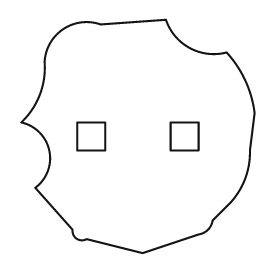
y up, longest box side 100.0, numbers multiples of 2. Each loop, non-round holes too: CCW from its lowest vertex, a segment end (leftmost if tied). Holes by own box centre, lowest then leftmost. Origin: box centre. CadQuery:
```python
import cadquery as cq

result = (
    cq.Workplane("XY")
    .moveTo(2.0, -50.0)
    .lineTo(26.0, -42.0)
    .threePointArc((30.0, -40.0), (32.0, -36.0))
    .lineTo(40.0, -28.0)
    .threePointArc((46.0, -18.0), (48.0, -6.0))
    .lineTo(50.0, 10.0)
    .threePointArc((46.0, 24.0), (38.0, 36.0))
    .threePointArc((22.0, 38.0), (12.0, 50.0))
    .lineTo(-16.0, 48.0)
    .threePointArc((-32.0, 46.0), (-40.0, 32.0))
    .threePointArc((-42.0, 18.0), (-50.0, 6.0))
    .threePointArc((-38.0, -6.0), (-44.0, -22.0))
    .lineTo(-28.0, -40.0)
    .threePointArc((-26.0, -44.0), (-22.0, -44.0))
    .close()
    .moveTo(-26.0, -6.0)
    .lineTo(-14.0, -6.0)
    .lineTo(-14.0, 6.0)
    .lineTo(-26.0, 6.0)
    .close()
    .moveTo(14.0, -6.0)
    .lineTo(26.0, -6.0)
    .lineTo(26.0, 6.0)
    .lineTo(14.0, 6.0)
    .close()
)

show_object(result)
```